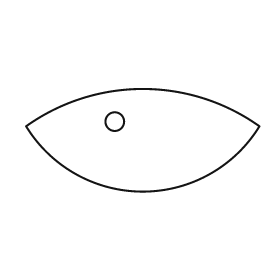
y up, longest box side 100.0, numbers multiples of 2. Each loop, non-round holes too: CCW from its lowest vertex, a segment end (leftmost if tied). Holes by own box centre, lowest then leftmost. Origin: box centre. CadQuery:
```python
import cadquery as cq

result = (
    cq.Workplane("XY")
    .moveTo(-50.0, 6.0)
    .threePointArc((0.0, -22.0), (50.0, 6.0))
    .threePointArc((0.0, 22.0), (-50.0, 6.0))
    .close()
    .moveTo(-12.0, 8.0)
    .circle(4.0)
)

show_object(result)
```